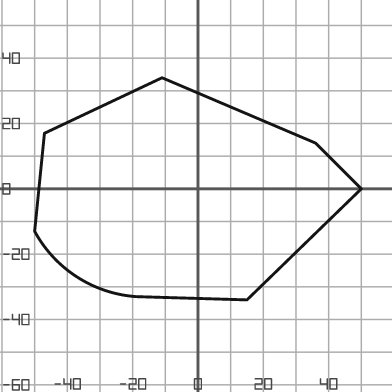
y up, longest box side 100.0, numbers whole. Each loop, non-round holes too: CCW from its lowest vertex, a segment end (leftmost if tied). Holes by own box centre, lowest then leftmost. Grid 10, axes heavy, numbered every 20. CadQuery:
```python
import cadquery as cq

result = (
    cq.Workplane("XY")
    .moveTo(15.0, -34.0)
    .lineTo(50.0, 0.0)
    .lineTo(36.0, 14.0)
    .lineTo(-11.0, 34.0)
    .lineTo(-47.0, 17.0)
    .lineTo(-50.0, -13.0)
    .threePointArc((-37.0, -27.0), (-19.0, -33.0))
    .close()
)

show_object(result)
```